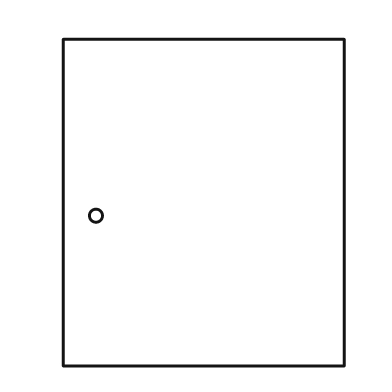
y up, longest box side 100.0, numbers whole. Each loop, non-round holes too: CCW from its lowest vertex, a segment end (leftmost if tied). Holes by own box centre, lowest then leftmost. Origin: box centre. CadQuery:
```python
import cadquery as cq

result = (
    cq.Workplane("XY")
    .moveTo(-43.0, -50.0)
    .lineTo(43.0, -50.0)
    .lineTo(43.0, 50.0)
    .lineTo(-43.0, 50.0)
    .close()
    .moveTo(-33.0, -4.0)
    .circle(2.0)
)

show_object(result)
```